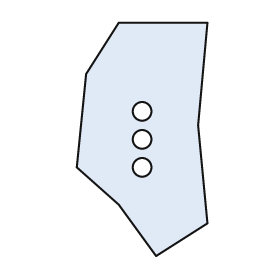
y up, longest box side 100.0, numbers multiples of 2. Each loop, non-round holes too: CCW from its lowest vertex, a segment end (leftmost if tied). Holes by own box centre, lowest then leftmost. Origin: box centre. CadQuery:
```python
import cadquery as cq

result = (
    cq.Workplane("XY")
    .moveTo(6.0, -50.0)
    .lineTo(28.0, -36.0)
    .lineTo(24.0, 6.0)
    .lineTo(28.0, 50.0)
    .lineTo(-10.0, 50.0)
    .lineTo(-24.0, 28.0)
    .lineTo(-28.0, -12.0)
    .lineTo(-10.0, -28.0)
    .close()
    .moveTo(0.0, -12.0)
    .circle(4.0)
    .moveTo(0.0, 0.0)
    .circle(4.0)
    .moveTo(0.0, 12.0)
    .circle(4.0)
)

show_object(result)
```